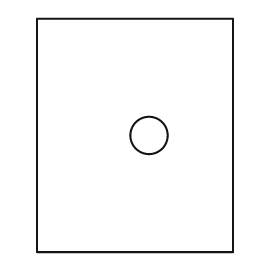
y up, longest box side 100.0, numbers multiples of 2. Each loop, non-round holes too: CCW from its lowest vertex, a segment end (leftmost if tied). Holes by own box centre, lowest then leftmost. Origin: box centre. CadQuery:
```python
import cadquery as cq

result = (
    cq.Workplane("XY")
    .moveTo(-42.0, -50.0)
    .lineTo(42.0, -50.0)
    .lineTo(42.0, 50.0)
    .lineTo(-42.0, 50.0)
    .close()
    .moveTo(6.0, 0.0)
    .circle(8.0)
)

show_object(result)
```